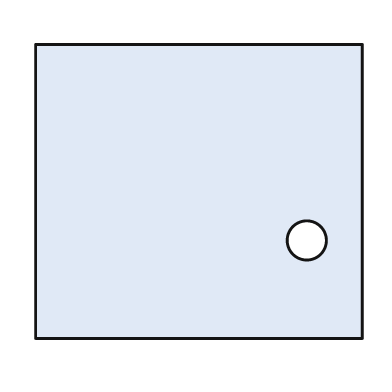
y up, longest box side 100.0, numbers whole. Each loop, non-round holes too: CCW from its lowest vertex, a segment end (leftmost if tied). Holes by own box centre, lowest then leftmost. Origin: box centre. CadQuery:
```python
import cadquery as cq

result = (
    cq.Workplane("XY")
    .moveTo(-50.0, -45.0)
    .lineTo(50.0, -45.0)
    .lineTo(50.0, 45.0)
    .lineTo(-50.0, 45.0)
    .close()
    .moveTo(33.0, -15.0)
    .circle(6.0)
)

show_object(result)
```